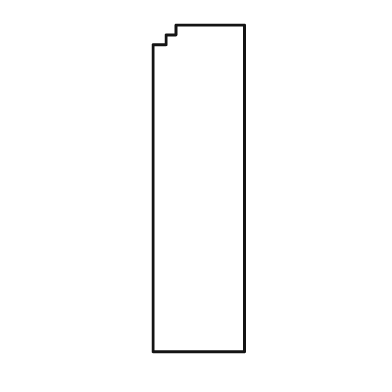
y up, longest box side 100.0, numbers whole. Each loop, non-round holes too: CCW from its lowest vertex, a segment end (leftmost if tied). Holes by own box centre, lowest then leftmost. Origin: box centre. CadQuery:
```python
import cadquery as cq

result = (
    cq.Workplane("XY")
    .moveTo(-14.0, -50.0)
    .lineTo(14.0, -50.0)
    .lineTo(14.0, 50.0)
    .lineTo(-7.0, 50.0)
    .lineTo(-7.0, 47.0)
    .lineTo(-10.0, 47.0)
    .lineTo(-10.0, 44.0)
    .lineTo(-14.0, 44.0)
    .close()
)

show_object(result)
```